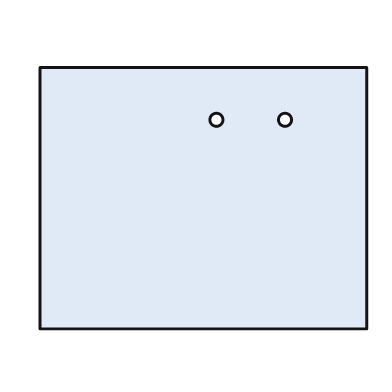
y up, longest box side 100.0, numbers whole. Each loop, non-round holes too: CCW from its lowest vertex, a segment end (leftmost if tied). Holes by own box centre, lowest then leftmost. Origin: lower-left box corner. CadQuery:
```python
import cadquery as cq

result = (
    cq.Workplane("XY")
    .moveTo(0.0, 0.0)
    .lineTo(100.0, 0.0)
    .lineTo(100.0, 80.0)
    .lineTo(0.0, 80.0)
    .close()
    .moveTo(54.0, 64.0)
    .circle(2.0)
    .moveTo(75.0, 64.0)
    .circle(2.0)
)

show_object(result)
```